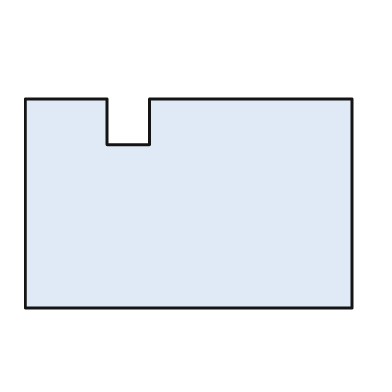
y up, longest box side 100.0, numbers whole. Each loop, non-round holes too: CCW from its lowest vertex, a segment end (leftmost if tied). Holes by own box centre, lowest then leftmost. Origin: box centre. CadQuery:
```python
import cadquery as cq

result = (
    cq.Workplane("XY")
    .moveTo(-50.0, -32.0)
    .lineTo(50.0, -32.0)
    .lineTo(50.0, 32.0)
    .lineTo(-12.0, 32.0)
    .lineTo(-12.0, 18.0)
    .lineTo(-25.0, 18.0)
    .lineTo(-25.0, 32.0)
    .lineTo(-50.0, 32.0)
    .close()
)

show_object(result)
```